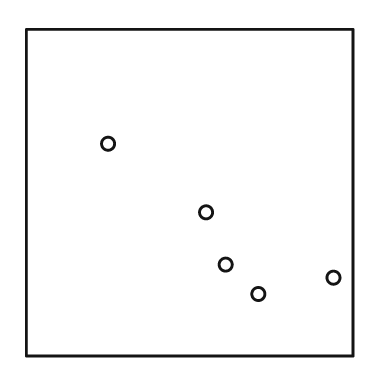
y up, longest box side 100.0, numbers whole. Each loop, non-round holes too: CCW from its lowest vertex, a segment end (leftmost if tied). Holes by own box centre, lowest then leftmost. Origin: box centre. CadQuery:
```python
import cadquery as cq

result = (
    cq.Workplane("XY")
    .moveTo(-50.0, -50.0)
    .lineTo(50.0, -50.0)
    .lineTo(50.0, 50.0)
    .lineTo(-50.0, 50.0)
    .close()
    .moveTo(21.0, -31.0)
    .circle(2.0)
    .moveTo(44.0, -26.0)
    .circle(2.0)
    .moveTo(11.0, -22.0)
    .circle(2.0)
    .moveTo(5.0, -6.0)
    .circle(2.0)
    .moveTo(-25.0, 15.0)
    .circle(2.0)
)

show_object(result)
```